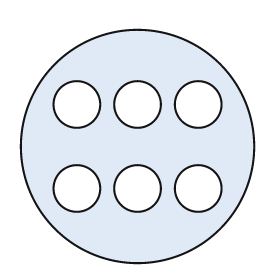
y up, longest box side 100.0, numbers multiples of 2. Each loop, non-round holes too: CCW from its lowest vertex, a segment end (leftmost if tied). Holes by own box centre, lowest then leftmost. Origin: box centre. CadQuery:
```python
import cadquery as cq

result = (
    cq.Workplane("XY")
    .moveTo(0.0, 0.0)
    .circle(50.0)
    .moveTo(-26.0, -18.0)
    .circle(10.0)
    .moveTo(0.0, -18.0)
    .circle(10.0)
    .moveTo(26.0, -18.0)
    .circle(10.0)
    .moveTo(-26.0, 18.0)
    .circle(10.0)
    .moveTo(0.0, 18.0)
    .circle(10.0)
    .moveTo(26.0, 18.0)
    .circle(10.0)
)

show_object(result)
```